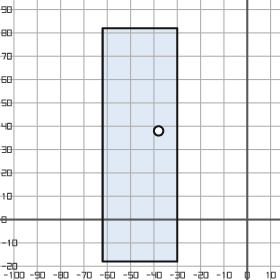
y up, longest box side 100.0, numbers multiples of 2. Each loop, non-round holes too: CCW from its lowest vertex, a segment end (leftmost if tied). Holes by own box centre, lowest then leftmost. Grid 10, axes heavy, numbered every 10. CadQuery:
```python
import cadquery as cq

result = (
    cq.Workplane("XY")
    .moveTo(-62.0, -18.0)
    .lineTo(-30.0, -18.0)
    .lineTo(-30.0, 82.0)
    .lineTo(-62.0, 82.0)
    .close()
    .moveTo(-38.0, 38.0)
    .circle(2.0)
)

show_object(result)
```